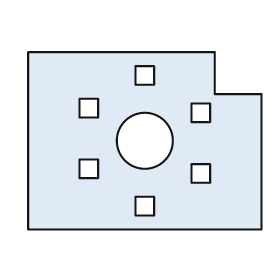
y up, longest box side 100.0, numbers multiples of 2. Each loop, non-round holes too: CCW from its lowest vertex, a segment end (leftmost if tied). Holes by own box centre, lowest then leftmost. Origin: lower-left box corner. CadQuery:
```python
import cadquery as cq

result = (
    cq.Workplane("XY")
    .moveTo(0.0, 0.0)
    .lineTo(100.0, 0.0)
    .lineTo(100.0, 58.0)
    .lineTo(80.0, 58.0)
    .lineTo(80.0, 76.0)
    .lineTo(0.0, 76.0)
    .close()
    .moveTo(46.0, 6.0)
    .lineTo(54.0, 6.0)
    .lineTo(54.0, 14.0)
    .lineTo(46.0, 14.0)
    .close()
    .moveTo(70.0, 20.0)
    .lineTo(78.0, 20.0)
    .lineTo(78.0, 28.0)
    .lineTo(70.0, 28.0)
    .close()
    .moveTo(22.0, 22.0)
    .lineTo(30.0, 22.0)
    .lineTo(30.0, 30.0)
    .lineTo(22.0, 30.0)
    .close()
    .moveTo(50.0, 38.0)
    .circle(12.0)
    .moveTo(70.0, 46.0)
    .lineTo(78.0, 46.0)
    .lineTo(78.0, 54.0)
    .lineTo(70.0, 54.0)
    .close()
    .moveTo(22.0, 48.0)
    .lineTo(30.0, 48.0)
    .lineTo(30.0, 56.0)
    .lineTo(22.0, 56.0)
    .close()
    .moveTo(46.0, 62.0)
    .lineTo(54.0, 62.0)
    .lineTo(54.0, 70.0)
    .lineTo(46.0, 70.0)
    .close()
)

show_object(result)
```